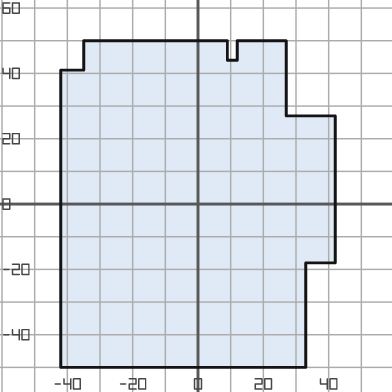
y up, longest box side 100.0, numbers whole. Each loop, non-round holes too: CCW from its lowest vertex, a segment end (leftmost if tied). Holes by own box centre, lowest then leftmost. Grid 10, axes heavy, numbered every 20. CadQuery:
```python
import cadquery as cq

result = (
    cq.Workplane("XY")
    .moveTo(-42.0, -50.0)
    .lineTo(33.0, -50.0)
    .lineTo(33.0, -18.0)
    .lineTo(42.0, -18.0)
    .lineTo(42.0, 27.0)
    .lineTo(27.0, 27.0)
    .lineTo(27.0, 50.0)
    .lineTo(12.0, 50.0)
    .lineTo(12.0, 44.0)
    .lineTo(9.0, 44.0)
    .lineTo(9.0, 50.0)
    .lineTo(-35.0, 50.0)
    .lineTo(-35.0, 41.0)
    .lineTo(-42.0, 41.0)
    .close()
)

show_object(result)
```